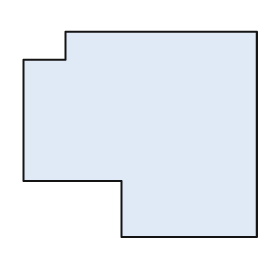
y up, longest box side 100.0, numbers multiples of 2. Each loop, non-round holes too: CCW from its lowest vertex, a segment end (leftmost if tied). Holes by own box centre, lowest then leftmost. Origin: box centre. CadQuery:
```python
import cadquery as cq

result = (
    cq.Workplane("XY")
    .moveTo(-8.0, -44.0)
    .lineTo(50.0, -44.0)
    .lineTo(50.0, 44.0)
    .lineTo(-32.0, 44.0)
    .lineTo(-32.0, 32.0)
    .lineTo(-50.0, 32.0)
    .lineTo(-50.0, -20.0)
    .lineTo(-8.0, -20.0)
    .close()
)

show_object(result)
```